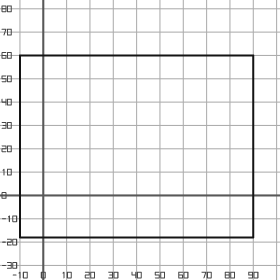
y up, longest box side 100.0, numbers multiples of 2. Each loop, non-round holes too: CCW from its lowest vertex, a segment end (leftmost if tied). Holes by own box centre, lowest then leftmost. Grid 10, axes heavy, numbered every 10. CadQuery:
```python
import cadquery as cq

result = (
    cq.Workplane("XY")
    .moveTo(-10.0, -18.0)
    .lineTo(90.0, -18.0)
    .lineTo(90.0, 60.0)
    .lineTo(-10.0, 60.0)
    .close()
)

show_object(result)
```